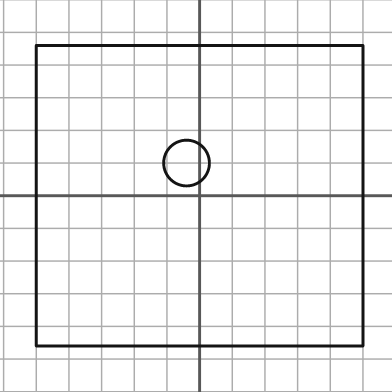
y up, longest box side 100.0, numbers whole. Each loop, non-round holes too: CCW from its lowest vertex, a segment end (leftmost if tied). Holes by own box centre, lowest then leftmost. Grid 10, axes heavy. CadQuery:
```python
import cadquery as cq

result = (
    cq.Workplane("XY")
    .moveTo(-50.0, -46.0)
    .lineTo(50.0, -46.0)
    .lineTo(50.0, 46.0)
    .lineTo(-50.0, 46.0)
    .close()
    .moveTo(-4.0, 10.0)
    .circle(7.0)
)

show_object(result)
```